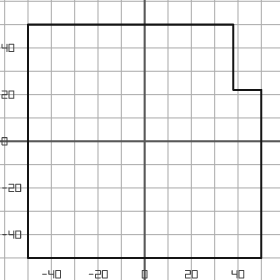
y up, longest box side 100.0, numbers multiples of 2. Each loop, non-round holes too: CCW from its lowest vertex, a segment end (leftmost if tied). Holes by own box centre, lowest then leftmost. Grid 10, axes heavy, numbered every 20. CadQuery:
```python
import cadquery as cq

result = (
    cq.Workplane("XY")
    .moveTo(-50.0, -50.0)
    .lineTo(50.0, -50.0)
    .lineTo(50.0, 22.0)
    .lineTo(38.0, 22.0)
    .lineTo(38.0, 50.0)
    .lineTo(-50.0, 50.0)
    .close()
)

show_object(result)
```